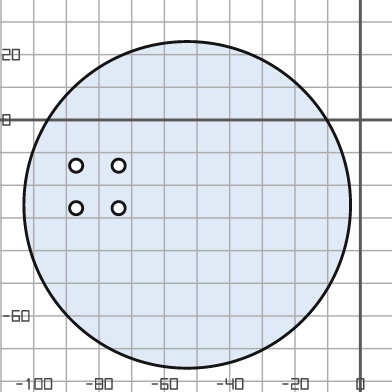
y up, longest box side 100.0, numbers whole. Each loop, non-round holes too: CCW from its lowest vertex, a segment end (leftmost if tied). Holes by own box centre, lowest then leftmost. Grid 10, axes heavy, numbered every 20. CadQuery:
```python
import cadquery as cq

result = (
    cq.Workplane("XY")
    .moveTo(-53.0, -26.0)
    .circle(50.0)
    .moveTo(-87.0, -27.0)
    .circle(2.0)
    .moveTo(-74.0, -27.0)
    .circle(2.0)
    .moveTo(-87.0, -14.0)
    .circle(2.0)
    .moveTo(-74.0, -14.0)
    .circle(2.0)
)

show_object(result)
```